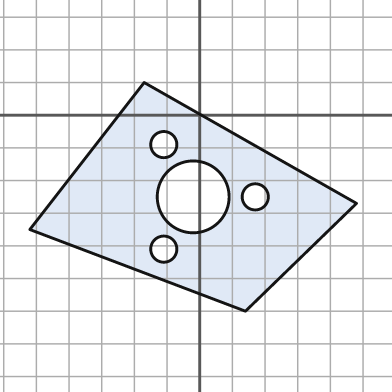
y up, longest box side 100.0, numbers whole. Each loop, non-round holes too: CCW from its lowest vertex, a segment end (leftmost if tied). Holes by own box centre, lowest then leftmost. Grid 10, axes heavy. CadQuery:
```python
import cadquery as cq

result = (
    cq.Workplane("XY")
    .moveTo(14.0, -60.0)
    .lineTo(48.0, -27.0)
    .lineTo(-17.0, 10.0)
    .lineTo(-52.0, -35.0)
    .close()
    .moveTo(-11.0, -41.0)
    .circle(4.0)
    .moveTo(-2.0, -25.0)
    .circle(11.0)
    .moveTo(17.0, -25.0)
    .circle(4.0)
    .moveTo(-11.0, -9.0)
    .circle(4.0)
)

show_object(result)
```